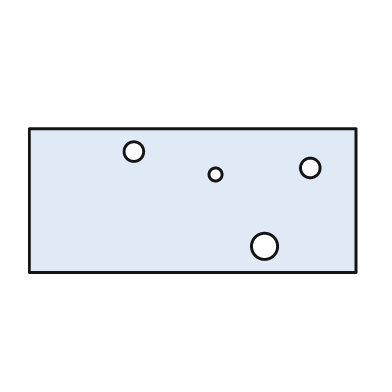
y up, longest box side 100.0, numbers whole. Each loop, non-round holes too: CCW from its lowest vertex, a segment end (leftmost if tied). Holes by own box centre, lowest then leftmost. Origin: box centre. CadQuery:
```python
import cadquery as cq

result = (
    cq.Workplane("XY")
    .moveTo(-50.0, -22.0)
    .lineTo(50.0, -22.0)
    .lineTo(50.0, 22.0)
    .lineTo(-50.0, 22.0)
    .close()
    .moveTo(22.0, -14.0)
    .circle(4.0)
    .moveTo(7.0, 8.0)
    .circle(2.0)
    .moveTo(36.0, 10.0)
    .circle(3.0)
    .moveTo(-18.0, 15.0)
    .circle(3.0)
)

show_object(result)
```